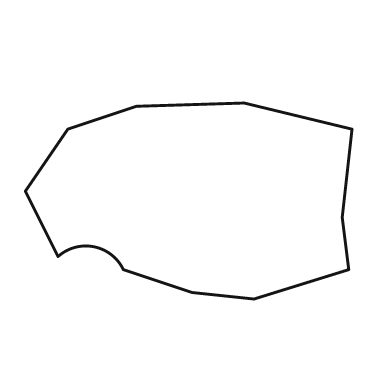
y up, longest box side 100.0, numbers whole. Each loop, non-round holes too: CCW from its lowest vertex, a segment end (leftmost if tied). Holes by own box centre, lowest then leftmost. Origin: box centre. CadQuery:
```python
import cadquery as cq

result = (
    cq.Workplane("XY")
    .moveTo(20.0, -30.0)
    .lineTo(49.0, -21.0)
    .lineTo(47.0, -5.0)
    .lineTo(50.0, 22.0)
    .lineTo(17.0, 30.0)
    .lineTo(-16.0, 29.0)
    .lineTo(-37.0, 22.0)
    .lineTo(-50.0, 3.0)
    .lineTo(-40.0, -17.0)
    .threePointArc((-29.0, -14.0), (-20.0, -21.0))
    .lineTo(1.0, -28.0)
    .close()
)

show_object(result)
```